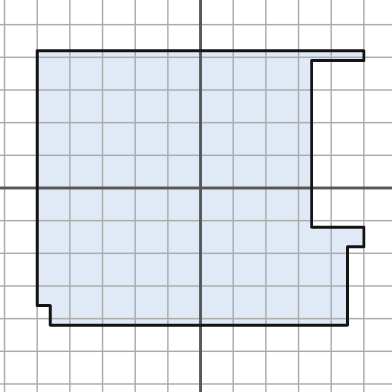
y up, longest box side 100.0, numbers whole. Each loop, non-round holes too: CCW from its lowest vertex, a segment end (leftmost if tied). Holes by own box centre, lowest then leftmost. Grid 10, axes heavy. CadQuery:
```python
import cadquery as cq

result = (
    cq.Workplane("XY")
    .moveTo(-46.0, -42.0)
    .lineTo(45.0, -42.0)
    .lineTo(45.0, -18.0)
    .lineTo(50.0, -18.0)
    .lineTo(50.0, -12.0)
    .lineTo(34.0, -12.0)
    .lineTo(34.0, 39.0)
    .lineTo(50.0, 39.0)
    .lineTo(50.0, 42.0)
    .lineTo(-50.0, 42.0)
    .lineTo(-50.0, -36.0)
    .lineTo(-46.0, -36.0)
    .close()
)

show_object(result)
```